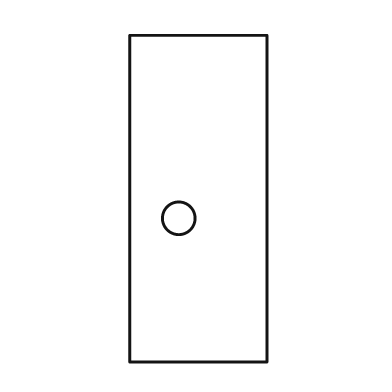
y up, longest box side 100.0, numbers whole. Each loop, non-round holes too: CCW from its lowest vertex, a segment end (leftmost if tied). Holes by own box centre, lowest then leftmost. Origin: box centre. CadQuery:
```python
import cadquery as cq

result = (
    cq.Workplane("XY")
    .moveTo(-21.0, -50.0)
    .lineTo(21.0, -50.0)
    .lineTo(21.0, 50.0)
    .lineTo(-21.0, 50.0)
    .close()
    .moveTo(-6.0, -6.0)
    .circle(5.0)
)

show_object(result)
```